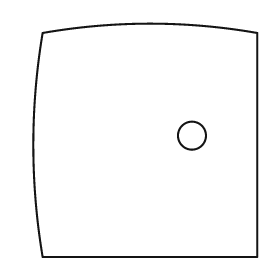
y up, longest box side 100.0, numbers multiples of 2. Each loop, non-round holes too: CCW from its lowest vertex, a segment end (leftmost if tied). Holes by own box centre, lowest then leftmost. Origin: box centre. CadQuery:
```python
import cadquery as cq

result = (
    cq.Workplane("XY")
    .moveTo(-44.0, -50.0)
    .lineTo(48.0, -50.0)
    .lineTo(48.0, 46.0)
    .threePointArc((2.0, 50.0), (-44.0, 46.0))
    .threePointArc((-48.0, -2.0), (-44.0, -50.0))
    .close()
    .moveTo(20.0, 2.0)
    .circle(6.0)
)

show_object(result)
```